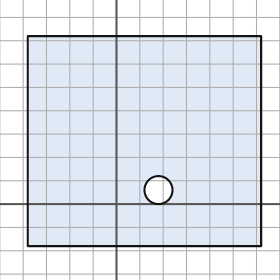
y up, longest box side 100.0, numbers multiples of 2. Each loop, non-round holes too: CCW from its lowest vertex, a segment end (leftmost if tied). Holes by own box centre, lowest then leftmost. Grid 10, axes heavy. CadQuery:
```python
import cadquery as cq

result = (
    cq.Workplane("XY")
    .moveTo(-38.0, -18.0)
    .lineTo(62.0, -18.0)
    .lineTo(62.0, 72.0)
    .lineTo(-38.0, 72.0)
    .close()
    .moveTo(18.0, 6.0)
    .circle(6.0)
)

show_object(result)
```